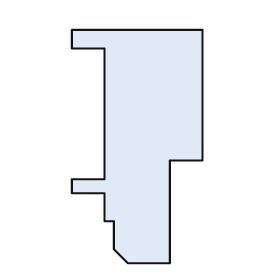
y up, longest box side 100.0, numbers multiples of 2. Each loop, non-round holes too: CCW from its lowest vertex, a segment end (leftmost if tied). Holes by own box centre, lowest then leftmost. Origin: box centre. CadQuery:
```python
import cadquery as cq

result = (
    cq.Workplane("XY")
    .moveTo(-4.0, -50.0)
    .lineTo(14.0, -50.0)
    .lineTo(14.0, -6.0)
    .lineTo(28.0, -6.0)
    .lineTo(28.0, 50.0)
    .lineTo(-28.0, 50.0)
    .lineTo(-28.0, 42.0)
    .lineTo(-14.0, 42.0)
    .lineTo(-14.0, -14.0)
    .lineTo(-28.0, -14.0)
    .lineTo(-28.0, -20.0)
    .lineTo(-14.0, -20.0)
    .lineTo(-14.0, -32.0)
    .lineTo(-10.0, -32.0)
    .lineTo(-10.0, -44.0)
    .close()
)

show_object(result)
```